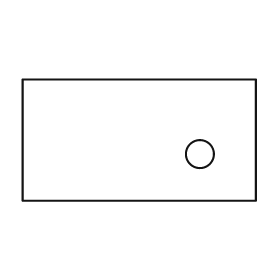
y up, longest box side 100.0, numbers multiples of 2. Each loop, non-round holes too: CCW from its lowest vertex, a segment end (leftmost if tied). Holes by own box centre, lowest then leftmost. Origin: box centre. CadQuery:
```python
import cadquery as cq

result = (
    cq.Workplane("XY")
    .moveTo(-50.0, -26.0)
    .lineTo(50.0, -26.0)
    .lineTo(50.0, 26.0)
    .lineTo(-50.0, 26.0)
    .close()
    .moveTo(26.0, -6.0)
    .circle(6.0)
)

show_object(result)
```